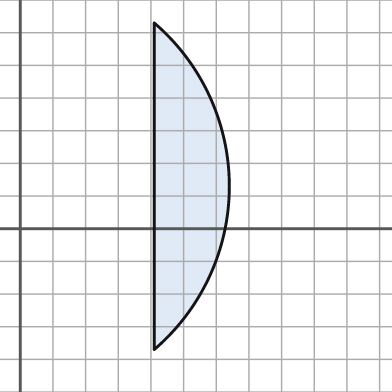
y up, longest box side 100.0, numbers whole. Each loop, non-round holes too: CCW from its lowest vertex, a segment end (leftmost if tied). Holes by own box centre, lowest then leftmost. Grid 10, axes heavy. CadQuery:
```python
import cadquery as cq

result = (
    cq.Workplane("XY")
    .moveTo(41.0, -37.0)
    .threePointArc((64.0, 13.0), (41.0, 63.0))
    .close()
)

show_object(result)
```